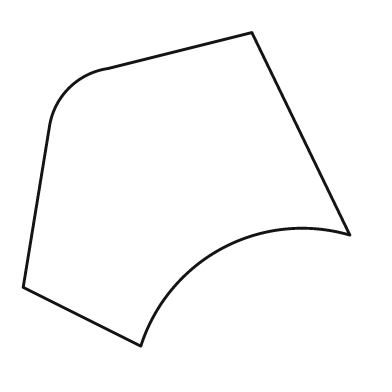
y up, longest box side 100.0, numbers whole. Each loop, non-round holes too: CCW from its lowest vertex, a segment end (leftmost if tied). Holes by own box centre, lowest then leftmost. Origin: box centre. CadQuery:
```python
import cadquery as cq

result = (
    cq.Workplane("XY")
    .moveTo(-14.0, -48.0)
    .threePointArc((11.0, -18.0), (50.0, -14.0))
    .lineTo(20.0, 48.0)
    .lineTo(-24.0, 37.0)
    .threePointArc((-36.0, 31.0), (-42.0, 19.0))
    .lineTo(-50.0, -30.0)
    .close()
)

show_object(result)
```